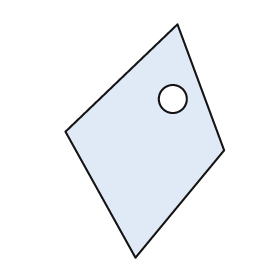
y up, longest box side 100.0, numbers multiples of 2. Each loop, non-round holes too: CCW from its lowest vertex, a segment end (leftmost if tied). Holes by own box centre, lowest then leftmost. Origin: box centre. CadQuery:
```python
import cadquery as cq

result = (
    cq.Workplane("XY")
    .moveTo(-4.0, -50.0)
    .lineTo(34.0, -4.0)
    .lineTo(14.0, 50.0)
    .lineTo(-34.0, 4.0)
    .close()
    .moveTo(12.0, 18.0)
    .circle(6.0)
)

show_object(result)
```